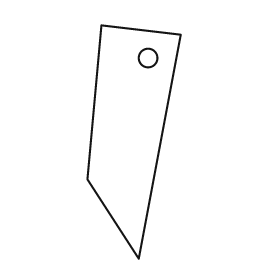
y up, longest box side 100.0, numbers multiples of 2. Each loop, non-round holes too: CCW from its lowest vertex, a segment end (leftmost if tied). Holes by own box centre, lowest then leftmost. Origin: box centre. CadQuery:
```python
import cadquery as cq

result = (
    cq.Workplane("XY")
    .moveTo(2.0, -50.0)
    .lineTo(20.0, 46.0)
    .lineTo(-14.0, 50.0)
    .lineTo(-20.0, -16.0)
    .close()
    .moveTo(6.0, 36.0)
    .circle(4.0)
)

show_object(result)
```